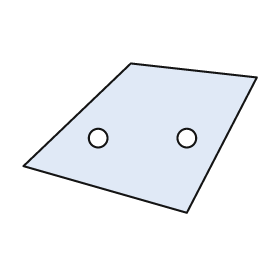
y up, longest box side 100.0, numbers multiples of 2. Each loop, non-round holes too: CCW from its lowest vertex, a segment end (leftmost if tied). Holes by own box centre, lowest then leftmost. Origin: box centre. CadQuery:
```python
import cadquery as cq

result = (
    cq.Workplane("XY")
    .moveTo(20.0, -32.0)
    .lineTo(50.0, 26.0)
    .lineTo(-4.0, 32.0)
    .lineTo(-50.0, -12.0)
    .close()
    .moveTo(-18.0, 0.0)
    .circle(4.0)
    .moveTo(20.0, 0.0)
    .circle(4.0)
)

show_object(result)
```